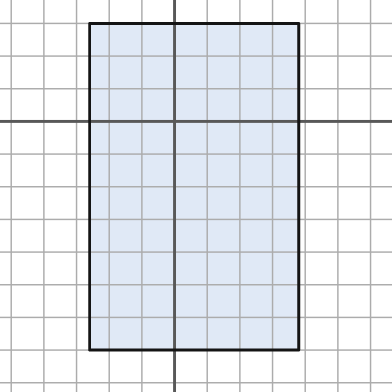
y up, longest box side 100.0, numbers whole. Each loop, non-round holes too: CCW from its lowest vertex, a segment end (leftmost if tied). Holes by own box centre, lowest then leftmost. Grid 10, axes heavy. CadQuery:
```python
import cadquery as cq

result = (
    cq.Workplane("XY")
    .moveTo(-26.0, -70.0)
    .lineTo(38.0, -70.0)
    .lineTo(38.0, 30.0)
    .lineTo(-26.0, 30.0)
    .close()
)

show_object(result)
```